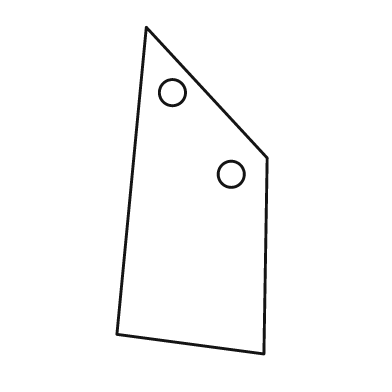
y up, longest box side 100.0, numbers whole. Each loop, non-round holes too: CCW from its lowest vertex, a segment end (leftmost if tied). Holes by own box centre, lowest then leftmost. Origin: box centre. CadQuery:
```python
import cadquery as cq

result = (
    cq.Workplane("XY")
    .moveTo(22.0, -50.0)
    .lineTo(23.0, 10.0)
    .lineTo(-14.0, 50.0)
    .lineTo(-23.0, -44.0)
    .close()
    .moveTo(12.0, 5.0)
    .circle(4.0)
    .moveTo(-6.0, 30.0)
    .circle(4.0)
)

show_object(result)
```